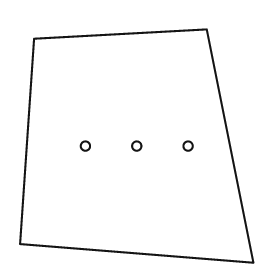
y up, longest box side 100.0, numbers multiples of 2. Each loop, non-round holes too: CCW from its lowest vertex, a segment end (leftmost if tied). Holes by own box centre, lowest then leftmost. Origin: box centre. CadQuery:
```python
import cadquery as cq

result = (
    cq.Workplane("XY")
    .moveTo(50.0, -50.0)
    .lineTo(30.0, 50.0)
    .lineTo(-44.0, 46.0)
    .lineTo(-50.0, -42.0)
    .close()
    .moveTo(-22.0, 0.0)
    .circle(2.0)
    .moveTo(0.0, 0.0)
    .circle(2.0)
    .moveTo(22.0, 0.0)
    .circle(2.0)
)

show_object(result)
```